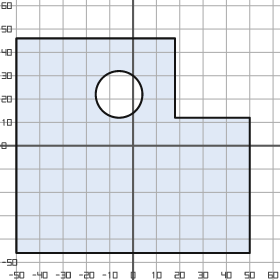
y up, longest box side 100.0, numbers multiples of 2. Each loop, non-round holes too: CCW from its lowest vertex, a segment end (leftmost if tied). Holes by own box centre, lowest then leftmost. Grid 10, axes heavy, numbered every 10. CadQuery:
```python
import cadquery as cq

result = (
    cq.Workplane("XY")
    .moveTo(-50.0, -46.0)
    .lineTo(50.0, -46.0)
    .lineTo(50.0, 12.0)
    .lineTo(18.0, 12.0)
    .lineTo(18.0, 46.0)
    .lineTo(-50.0, 46.0)
    .close()
    .moveTo(-6.0, 22.0)
    .circle(10.0)
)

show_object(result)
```